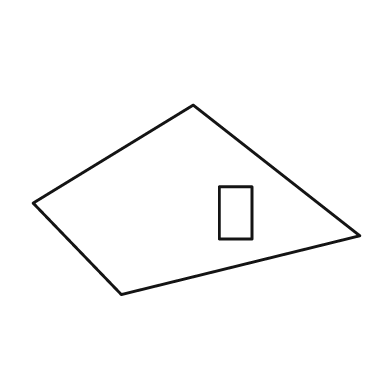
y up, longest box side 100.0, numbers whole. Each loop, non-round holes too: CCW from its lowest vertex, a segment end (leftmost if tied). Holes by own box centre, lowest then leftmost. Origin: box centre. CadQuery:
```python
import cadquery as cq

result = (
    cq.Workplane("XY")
    .moveTo(-23.0, -29.0)
    .lineTo(50.0, -11.0)
    .lineTo(-1.0, 29.0)
    .lineTo(-50.0, -1.0)
    .close()
    .moveTo(7.0, -12.0)
    .lineTo(17.0, -12.0)
    .lineTo(17.0, 4.0)
    .lineTo(7.0, 4.0)
    .close()
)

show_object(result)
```